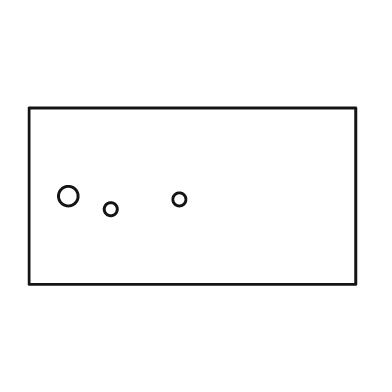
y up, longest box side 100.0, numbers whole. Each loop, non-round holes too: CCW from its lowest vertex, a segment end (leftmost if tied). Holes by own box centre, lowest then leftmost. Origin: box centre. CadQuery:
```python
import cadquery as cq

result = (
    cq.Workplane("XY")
    .moveTo(-50.0, -27.0)
    .lineTo(50.0, -27.0)
    .lineTo(50.0, 27.0)
    .lineTo(-50.0, 27.0)
    .close()
    .moveTo(-25.0, -4.0)
    .circle(2.0)
    .moveTo(-4.0, -1.0)
    .circle(2.0)
    .moveTo(-38.0, 0.0)
    .circle(3.0)
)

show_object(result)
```